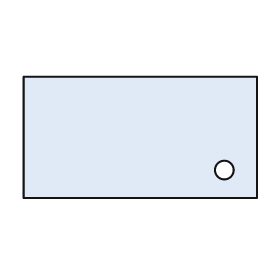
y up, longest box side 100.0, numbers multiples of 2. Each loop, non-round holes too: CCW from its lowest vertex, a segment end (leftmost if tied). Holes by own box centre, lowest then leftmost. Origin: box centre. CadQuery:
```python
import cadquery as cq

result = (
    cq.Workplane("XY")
    .moveTo(-50.0, -26.0)
    .lineTo(50.0, -26.0)
    .lineTo(50.0, 26.0)
    .lineTo(-50.0, 26.0)
    .close()
    .moveTo(36.0, -14.0)
    .circle(4.0)
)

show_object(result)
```